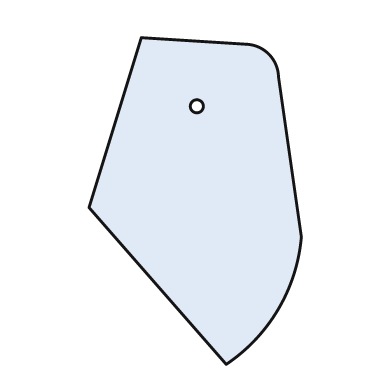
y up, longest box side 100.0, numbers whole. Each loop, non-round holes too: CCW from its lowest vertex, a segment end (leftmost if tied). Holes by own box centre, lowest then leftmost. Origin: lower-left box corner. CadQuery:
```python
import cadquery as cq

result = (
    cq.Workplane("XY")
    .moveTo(42.0, 0.0)
    .threePointArc((58.0, 17.0), (65.0, 39.0))
    .lineTo(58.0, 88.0)
    .threePointArc((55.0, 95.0), (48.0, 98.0))
    .lineTo(16.0, 100.0)
    .lineTo(0.0, 48.0)
    .close()
    .moveTo(33.0, 79.0)
    .circle(2.0)
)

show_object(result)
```